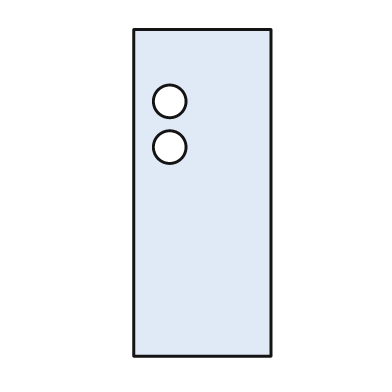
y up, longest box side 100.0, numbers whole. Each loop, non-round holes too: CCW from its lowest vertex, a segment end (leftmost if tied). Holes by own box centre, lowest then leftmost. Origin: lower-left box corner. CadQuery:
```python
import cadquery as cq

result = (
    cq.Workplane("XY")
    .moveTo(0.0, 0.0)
    .lineTo(42.0, 0.0)
    .lineTo(42.0, 100.0)
    .lineTo(0.0, 100.0)
    .close()
    .moveTo(11.0, 64.0)
    .circle(5.0)
    .moveTo(11.0, 78.0)
    .circle(5.0)
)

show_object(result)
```